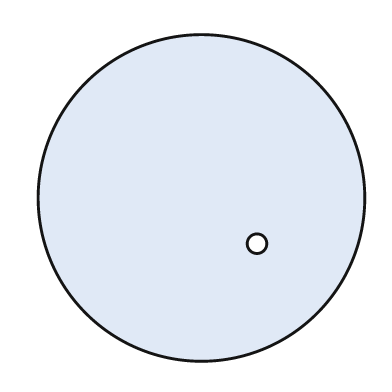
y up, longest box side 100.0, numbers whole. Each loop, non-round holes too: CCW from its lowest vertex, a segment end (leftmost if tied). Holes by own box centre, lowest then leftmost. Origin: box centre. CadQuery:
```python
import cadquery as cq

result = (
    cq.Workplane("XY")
    .moveTo(0.0, 0.0)
    .circle(50.0)
    .moveTo(17.0, -14.0)
    .circle(3.0)
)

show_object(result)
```